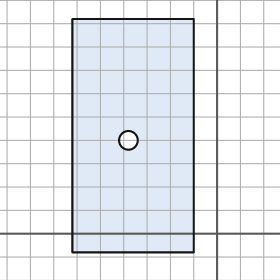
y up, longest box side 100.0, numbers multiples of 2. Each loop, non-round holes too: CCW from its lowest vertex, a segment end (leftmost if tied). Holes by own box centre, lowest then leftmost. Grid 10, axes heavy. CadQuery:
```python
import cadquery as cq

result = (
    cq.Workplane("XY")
    .moveTo(-62.0, -8.0)
    .lineTo(-10.0, -8.0)
    .lineTo(-10.0, 92.0)
    .lineTo(-62.0, 92.0)
    .close()
    .moveTo(-38.0, 40.0)
    .circle(4.0)
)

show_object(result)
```